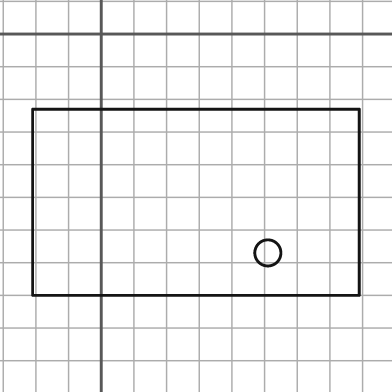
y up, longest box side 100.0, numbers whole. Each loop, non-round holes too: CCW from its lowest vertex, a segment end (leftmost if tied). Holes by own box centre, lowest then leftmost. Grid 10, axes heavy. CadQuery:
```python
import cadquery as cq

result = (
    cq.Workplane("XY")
    .moveTo(-21.0, -80.0)
    .lineTo(79.0, -80.0)
    .lineTo(79.0, -23.0)
    .lineTo(-21.0, -23.0)
    .close()
    .moveTo(51.0, -67.0)
    .circle(4.0)
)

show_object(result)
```